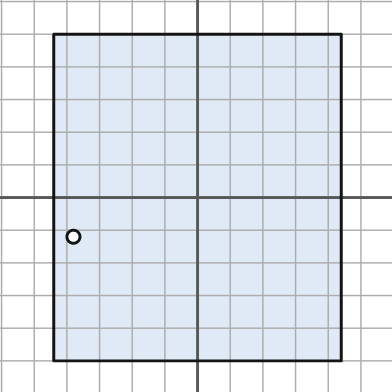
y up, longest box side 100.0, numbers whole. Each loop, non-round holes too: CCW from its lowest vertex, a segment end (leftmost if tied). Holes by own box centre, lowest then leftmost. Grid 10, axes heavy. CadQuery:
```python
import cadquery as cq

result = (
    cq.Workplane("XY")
    .moveTo(-44.0, -50.0)
    .lineTo(44.0, -50.0)
    .lineTo(44.0, 50.0)
    .lineTo(-44.0, 50.0)
    .close()
    .moveTo(-38.0, -12.0)
    .circle(2.0)
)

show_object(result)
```